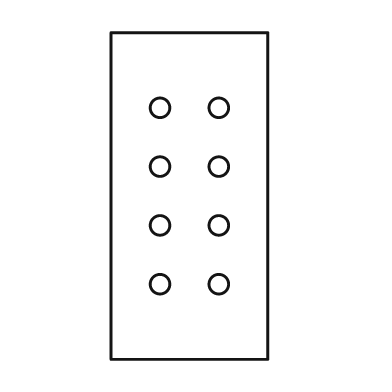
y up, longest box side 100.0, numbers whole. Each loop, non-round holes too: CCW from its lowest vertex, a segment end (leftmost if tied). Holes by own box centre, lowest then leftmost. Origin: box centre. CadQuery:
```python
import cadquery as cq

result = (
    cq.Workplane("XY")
    .moveTo(-24.0, -50.0)
    .lineTo(24.0, -50.0)
    .lineTo(24.0, 50.0)
    .lineTo(-24.0, 50.0)
    .close()
    .moveTo(-9.0, -27.0)
    .circle(3.0)
    .moveTo(9.0, -27.0)
    .circle(3.0)
    .moveTo(-9.0, -9.0)
    .circle(3.0)
    .moveTo(9.0, -9.0)
    .circle(3.0)
    .moveTo(-9.0, 9.0)
    .circle(3.0)
    .moveTo(9.0, 9.0)
    .circle(3.0)
    .moveTo(-9.0, 27.0)
    .circle(3.0)
    .moveTo(9.0, 27.0)
    .circle(3.0)
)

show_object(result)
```